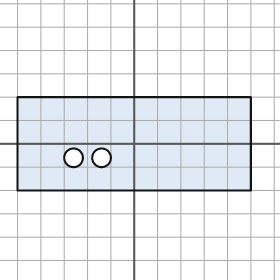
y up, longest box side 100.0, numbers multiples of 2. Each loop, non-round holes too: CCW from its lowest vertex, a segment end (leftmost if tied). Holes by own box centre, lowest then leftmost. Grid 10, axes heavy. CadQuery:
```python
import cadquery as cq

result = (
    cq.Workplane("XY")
    .moveTo(-50.0, -20.0)
    .lineTo(50.0, -20.0)
    .lineTo(50.0, 20.0)
    .lineTo(-50.0, 20.0)
    .close()
    .moveTo(-26.0, -6.0)
    .circle(4.0)
    .moveTo(-14.0, -6.0)
    .circle(4.0)
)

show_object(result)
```